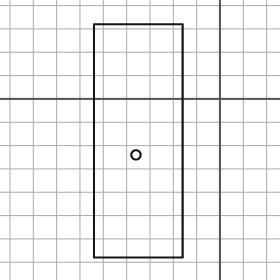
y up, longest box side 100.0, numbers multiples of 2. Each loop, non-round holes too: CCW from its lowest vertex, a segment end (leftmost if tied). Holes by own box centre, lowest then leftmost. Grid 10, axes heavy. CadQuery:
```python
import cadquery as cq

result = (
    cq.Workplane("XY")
    .moveTo(-54.0, -68.0)
    .lineTo(-16.0, -68.0)
    .lineTo(-16.0, 32.0)
    .lineTo(-54.0, 32.0)
    .close()
    .moveTo(-36.0, -24.0)
    .circle(2.0)
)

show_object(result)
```